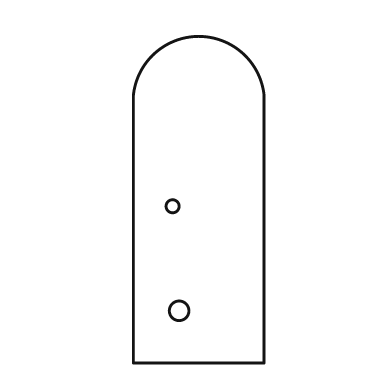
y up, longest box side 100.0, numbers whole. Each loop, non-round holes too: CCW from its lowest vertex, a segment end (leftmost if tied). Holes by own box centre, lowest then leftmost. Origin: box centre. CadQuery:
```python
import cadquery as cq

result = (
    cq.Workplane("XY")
    .moveTo(-20.0, -50.0)
    .lineTo(20.0, -50.0)
    .lineTo(20.0, 32.0)
    .threePointArc((0.0, 50.0), (-20.0, 32.0))
    .close()
    .moveTo(-6.0, -34.0)
    .circle(3.0)
    .moveTo(-8.0, -2.0)
    .circle(2.0)
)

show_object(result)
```